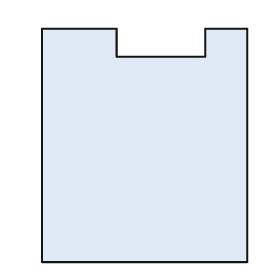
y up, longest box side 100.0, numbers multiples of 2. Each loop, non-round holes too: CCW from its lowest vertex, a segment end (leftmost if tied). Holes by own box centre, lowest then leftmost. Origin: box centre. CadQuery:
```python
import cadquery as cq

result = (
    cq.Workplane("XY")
    .moveTo(-44.0, -50.0)
    .lineTo(44.0, -50.0)
    .lineTo(44.0, 50.0)
    .lineTo(26.0, 50.0)
    .lineTo(26.0, 38.0)
    .lineTo(-12.0, 38.0)
    .lineTo(-12.0, 50.0)
    .lineTo(-44.0, 50.0)
    .close()
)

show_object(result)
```